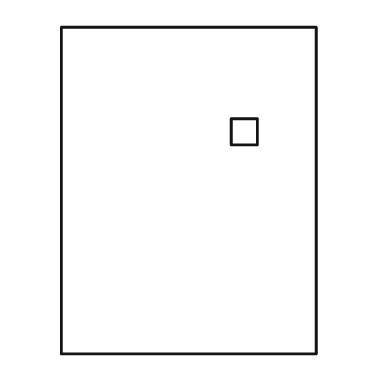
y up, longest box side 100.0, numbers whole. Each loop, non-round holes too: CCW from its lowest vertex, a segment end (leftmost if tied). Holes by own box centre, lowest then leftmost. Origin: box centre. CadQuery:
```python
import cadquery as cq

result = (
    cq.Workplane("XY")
    .moveTo(-39.0, -50.0)
    .lineTo(39.0, -50.0)
    .lineTo(39.0, 50.0)
    .lineTo(-39.0, 50.0)
    .close()
    .moveTo(13.0, 14.0)
    .lineTo(21.0, 14.0)
    .lineTo(21.0, 22.0)
    .lineTo(13.0, 22.0)
    .close()
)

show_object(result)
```